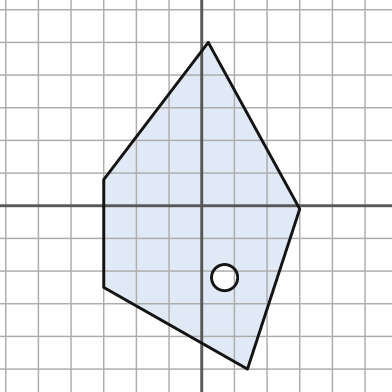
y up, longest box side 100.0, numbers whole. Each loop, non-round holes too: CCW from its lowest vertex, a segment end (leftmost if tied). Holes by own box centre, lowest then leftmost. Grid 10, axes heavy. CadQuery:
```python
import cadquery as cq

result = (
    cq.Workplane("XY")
    .moveTo(14.0, -50.0)
    .lineTo(30.0, -1.0)
    .lineTo(2.0, 50.0)
    .lineTo(-30.0, 8.0)
    .lineTo(-30.0, -25.0)
    .close()
    .moveTo(7.0, -22.0)
    .circle(4.0)
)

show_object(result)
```